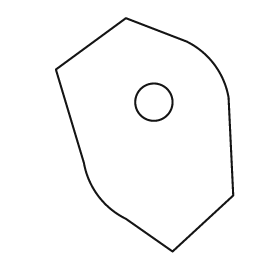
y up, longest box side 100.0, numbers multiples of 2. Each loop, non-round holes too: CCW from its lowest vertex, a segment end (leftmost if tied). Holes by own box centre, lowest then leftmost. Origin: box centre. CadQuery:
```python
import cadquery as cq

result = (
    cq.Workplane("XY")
    .moveTo(12.0, -50.0)
    .lineTo(38.0, -26.0)
    .lineTo(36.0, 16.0)
    .threePointArc((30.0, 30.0), (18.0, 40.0))
    .lineTo(-8.0, 50.0)
    .lineTo(-38.0, 28.0)
    .lineTo(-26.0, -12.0)
    .threePointArc((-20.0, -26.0), (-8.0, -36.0))
    .close()
    .moveTo(4.0, 14.0)
    .circle(8.0)
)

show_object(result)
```